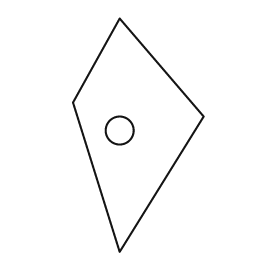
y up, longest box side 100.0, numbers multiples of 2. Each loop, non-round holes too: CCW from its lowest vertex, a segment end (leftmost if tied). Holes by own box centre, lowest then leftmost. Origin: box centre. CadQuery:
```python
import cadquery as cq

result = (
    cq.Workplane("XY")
    .moveTo(-8.0, -50.0)
    .lineTo(28.0, 8.0)
    .lineTo(-8.0, 50.0)
    .lineTo(-28.0, 14.0)
    .close()
    .moveTo(-8.0, 2.0)
    .circle(6.0)
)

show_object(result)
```